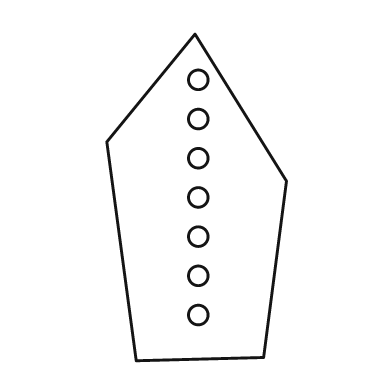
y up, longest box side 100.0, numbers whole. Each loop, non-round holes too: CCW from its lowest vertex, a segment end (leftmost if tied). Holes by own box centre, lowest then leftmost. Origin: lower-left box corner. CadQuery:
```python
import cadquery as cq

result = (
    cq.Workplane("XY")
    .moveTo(9.0, 0.0)
    .lineTo(48.0, 1.0)
    .lineTo(55.0, 55.0)
    .lineTo(27.0, 100.0)
    .lineTo(0.0, 67.0)
    .close()
    .moveTo(28.0, 14.0)
    .circle(3.0)
    .moveTo(28.0, 26.0)
    .circle(3.0)
    .moveTo(28.0, 38.0)
    .circle(3.0)
    .moveTo(28.0, 50.0)
    .circle(3.0)
    .moveTo(28.0, 62.0)
    .circle(3.0)
    .moveTo(28.0, 74.0)
    .circle(3.0)
    .moveTo(28.0, 86.0)
    .circle(3.0)
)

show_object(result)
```